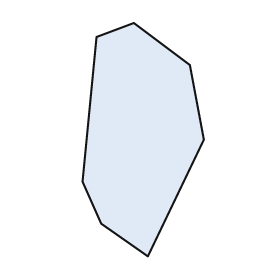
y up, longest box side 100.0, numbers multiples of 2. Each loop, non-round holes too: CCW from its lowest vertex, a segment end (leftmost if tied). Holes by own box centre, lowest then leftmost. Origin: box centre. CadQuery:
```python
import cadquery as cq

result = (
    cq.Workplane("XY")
    .moveTo(2.0, -50.0)
    .lineTo(26.0, 0.0)
    .lineTo(20.0, 32.0)
    .lineTo(-4.0, 50.0)
    .lineTo(-20.0, 44.0)
    .lineTo(-26.0, -18.0)
    .lineTo(-18.0, -36.0)
    .close()
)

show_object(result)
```